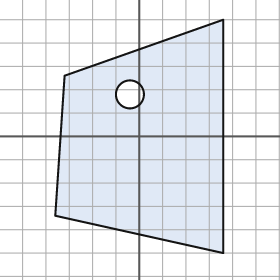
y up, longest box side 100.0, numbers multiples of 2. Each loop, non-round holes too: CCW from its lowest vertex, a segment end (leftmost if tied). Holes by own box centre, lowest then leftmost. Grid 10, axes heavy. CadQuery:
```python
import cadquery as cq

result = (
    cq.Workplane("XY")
    .moveTo(36.0, -50.0)
    .lineTo(36.0, 50.0)
    .lineTo(-32.0, 26.0)
    .lineTo(-36.0, -34.0)
    .close()
    .moveTo(-4.0, 18.0)
    .circle(6.0)
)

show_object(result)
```